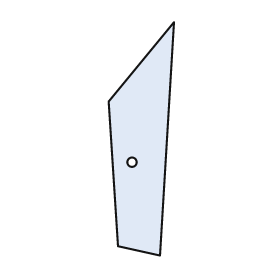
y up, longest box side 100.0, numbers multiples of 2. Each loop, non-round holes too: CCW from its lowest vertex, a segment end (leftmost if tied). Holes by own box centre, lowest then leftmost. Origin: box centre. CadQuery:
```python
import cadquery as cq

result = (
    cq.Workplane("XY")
    .moveTo(8.0, -50.0)
    .lineTo(14.0, 50.0)
    .lineTo(-14.0, 16.0)
    .lineTo(-10.0, -46.0)
    .close()
    .moveTo(-4.0, -10.0)
    .circle(2.0)
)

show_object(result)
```